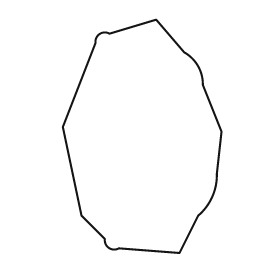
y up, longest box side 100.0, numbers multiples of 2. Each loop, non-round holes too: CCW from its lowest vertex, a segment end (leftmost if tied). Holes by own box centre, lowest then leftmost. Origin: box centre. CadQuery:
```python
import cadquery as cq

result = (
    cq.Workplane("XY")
    .moveTo(16.0, -50.0)
    .lineTo(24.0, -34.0)
    .threePointArc((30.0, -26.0), (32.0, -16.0))
    .lineTo(34.0, 2.0)
    .lineTo(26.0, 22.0)
    .threePointArc((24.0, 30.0), (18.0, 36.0))
    .lineTo(6.0, 50.0)
    .lineTo(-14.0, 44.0)
    .threePointArc((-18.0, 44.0), (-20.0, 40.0))
    .lineTo(-34.0, 4.0)
    .lineTo(-26.0, -34.0)
    .lineTo(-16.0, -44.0)
    .threePointArc((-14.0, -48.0), (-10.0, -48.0))
    .close()
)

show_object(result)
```